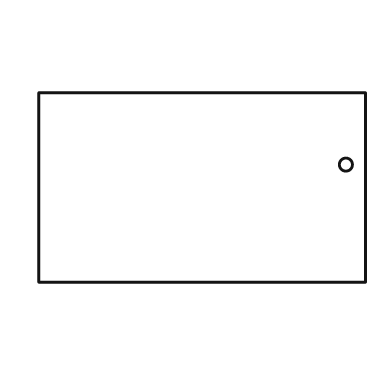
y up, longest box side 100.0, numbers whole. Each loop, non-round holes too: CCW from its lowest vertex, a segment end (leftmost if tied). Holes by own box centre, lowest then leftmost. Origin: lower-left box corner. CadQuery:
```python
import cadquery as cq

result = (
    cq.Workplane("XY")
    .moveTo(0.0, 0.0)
    .lineTo(100.0, 0.0)
    .lineTo(100.0, 58.0)
    .lineTo(0.0, 58.0)
    .close()
    .moveTo(94.0, 36.0)
    .circle(2.0)
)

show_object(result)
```